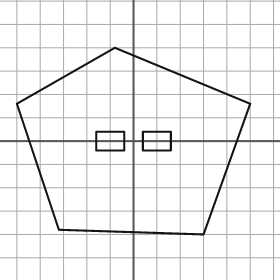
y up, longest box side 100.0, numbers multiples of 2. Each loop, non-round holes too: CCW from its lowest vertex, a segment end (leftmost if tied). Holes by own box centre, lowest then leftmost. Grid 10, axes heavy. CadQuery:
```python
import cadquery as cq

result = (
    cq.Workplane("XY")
    .moveTo(30.0, -40.0)
    .lineTo(50.0, 16.0)
    .lineTo(-8.0, 40.0)
    .lineTo(-50.0, 16.0)
    .lineTo(-32.0, -38.0)
    .close()
    .moveTo(-16.0, -4.0)
    .lineTo(-4.0, -4.0)
    .lineTo(-4.0, 4.0)
    .lineTo(-16.0, 4.0)
    .close()
    .moveTo(4.0, -4.0)
    .lineTo(16.0, -4.0)
    .lineTo(16.0, 4.0)
    .lineTo(4.0, 4.0)
    .close()
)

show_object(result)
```